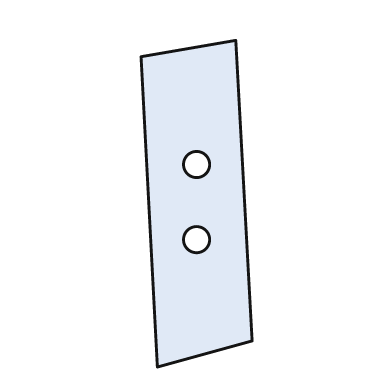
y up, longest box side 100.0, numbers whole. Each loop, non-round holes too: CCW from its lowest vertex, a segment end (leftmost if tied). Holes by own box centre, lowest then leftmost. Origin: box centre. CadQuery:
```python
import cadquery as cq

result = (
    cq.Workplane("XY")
    .moveTo(-12.0, -50.0)
    .lineTo(17.0, -42.0)
    .lineTo(12.0, 50.0)
    .lineTo(-17.0, 45.0)
    .close()
    .moveTo(0.0, -11.0)
    .circle(4.0)
    .moveTo(0.0, 12.0)
    .circle(4.0)
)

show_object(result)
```